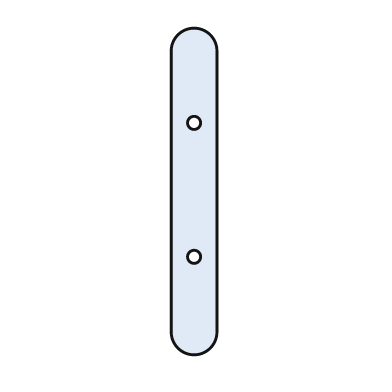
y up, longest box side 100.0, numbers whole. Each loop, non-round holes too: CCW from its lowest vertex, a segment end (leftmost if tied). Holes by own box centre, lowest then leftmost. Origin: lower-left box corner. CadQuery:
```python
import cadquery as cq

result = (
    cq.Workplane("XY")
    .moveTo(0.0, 7.0)
    .threePointArc((7.0, 0.0), (14.0, 7.0))
    .lineTo(14.0, 93.0)
    .threePointArc((7.0, 100.0), (0.0, 93.0))
    .close()
    .moveTo(7.0, 30.0)
    .circle(2.0)
    .moveTo(7.0, 71.0)
    .circle(2.0)
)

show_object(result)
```